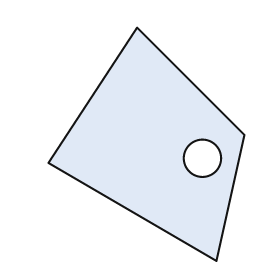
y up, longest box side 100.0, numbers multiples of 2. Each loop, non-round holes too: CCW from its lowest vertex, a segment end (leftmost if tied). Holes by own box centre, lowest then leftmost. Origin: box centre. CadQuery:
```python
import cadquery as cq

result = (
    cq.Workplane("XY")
    .moveTo(30.0, -50.0)
    .lineTo(42.0, 4.0)
    .lineTo(-4.0, 50.0)
    .lineTo(-42.0, -8.0)
    .close()
    .moveTo(24.0, -6.0)
    .circle(8.0)
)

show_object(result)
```